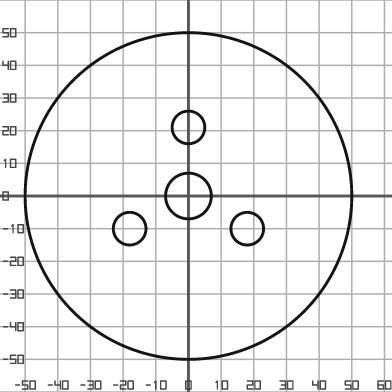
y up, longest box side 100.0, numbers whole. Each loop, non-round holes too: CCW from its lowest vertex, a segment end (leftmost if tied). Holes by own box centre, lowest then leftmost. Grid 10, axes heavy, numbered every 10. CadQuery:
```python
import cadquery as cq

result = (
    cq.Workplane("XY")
    .moveTo(0.0, 0.0)
    .circle(50.0)
    .moveTo(-18.0, -10.0)
    .circle(5.0)
    .moveTo(18.0, -10.0)
    .circle(5.0)
    .moveTo(0.0, 0.0)
    .circle(7.0)
    .moveTo(0.0, 21.0)
    .circle(5.0)
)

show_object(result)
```